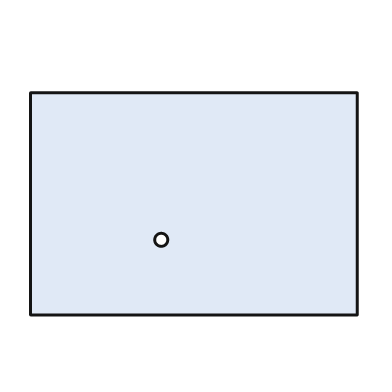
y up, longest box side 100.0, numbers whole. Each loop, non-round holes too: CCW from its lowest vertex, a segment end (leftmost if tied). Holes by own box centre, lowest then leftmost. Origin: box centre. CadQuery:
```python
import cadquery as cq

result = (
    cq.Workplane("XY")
    .moveTo(-50.0, -34.0)
    .lineTo(50.0, -34.0)
    .lineTo(50.0, 34.0)
    .lineTo(-50.0, 34.0)
    .close()
    .moveTo(-10.0, -11.0)
    .circle(2.0)
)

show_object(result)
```